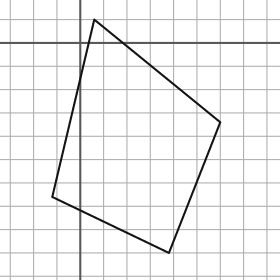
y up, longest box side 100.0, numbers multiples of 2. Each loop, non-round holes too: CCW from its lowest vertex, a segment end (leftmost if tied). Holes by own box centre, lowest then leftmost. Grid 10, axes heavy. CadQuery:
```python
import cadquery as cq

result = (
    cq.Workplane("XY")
    .moveTo(38.0, -90.0)
    .lineTo(60.0, -34.0)
    .lineTo(6.0, 10.0)
    .lineTo(-12.0, -66.0)
    .close()
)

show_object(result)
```